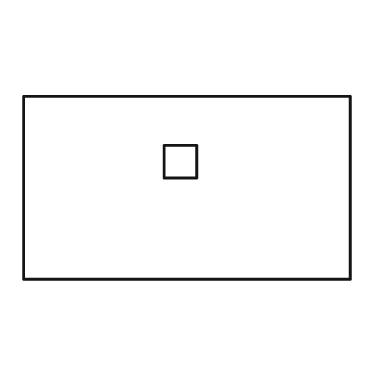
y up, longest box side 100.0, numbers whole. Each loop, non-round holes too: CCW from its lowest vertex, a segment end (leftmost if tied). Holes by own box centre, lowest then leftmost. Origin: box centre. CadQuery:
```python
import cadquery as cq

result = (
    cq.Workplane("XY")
    .moveTo(-50.0, -28.0)
    .lineTo(50.0, -28.0)
    .lineTo(50.0, 28.0)
    .lineTo(-50.0, 28.0)
    .close()
    .moveTo(-7.0, 3.0)
    .lineTo(3.0, 3.0)
    .lineTo(3.0, 13.0)
    .lineTo(-7.0, 13.0)
    .close()
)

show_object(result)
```